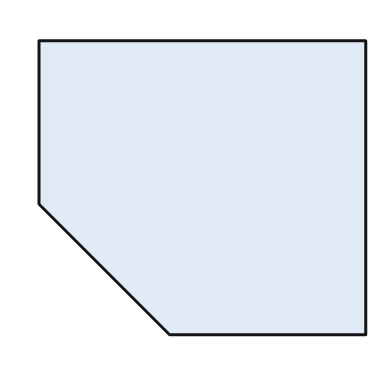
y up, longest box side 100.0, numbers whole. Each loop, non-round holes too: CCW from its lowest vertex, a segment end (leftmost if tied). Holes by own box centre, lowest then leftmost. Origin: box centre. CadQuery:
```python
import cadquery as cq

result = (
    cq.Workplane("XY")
    .moveTo(-10.0, -45.0)
    .lineTo(50.0, -45.0)
    .lineTo(50.0, 45.0)
    .lineTo(-50.0, 45.0)
    .lineTo(-50.0, -5.0)
    .close()
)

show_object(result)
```